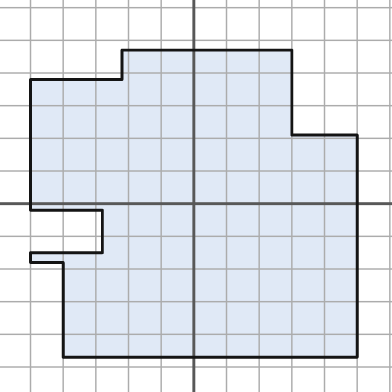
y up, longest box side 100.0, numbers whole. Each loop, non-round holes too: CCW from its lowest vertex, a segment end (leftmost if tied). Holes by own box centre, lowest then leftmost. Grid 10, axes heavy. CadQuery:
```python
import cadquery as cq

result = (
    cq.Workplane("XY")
    .moveTo(-40.0, -47.0)
    .lineTo(50.0, -47.0)
    .lineTo(50.0, 21.0)
    .lineTo(30.0, 21.0)
    .lineTo(30.0, 47.0)
    .lineTo(-22.0, 47.0)
    .lineTo(-22.0, 38.0)
    .lineTo(-50.0, 38.0)
    .lineTo(-50.0, -2.0)
    .lineTo(-28.0, -2.0)
    .lineTo(-28.0, -15.0)
    .lineTo(-50.0, -15.0)
    .lineTo(-50.0, -18.0)
    .lineTo(-40.0, -18.0)
    .close()
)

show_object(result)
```